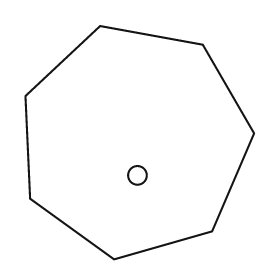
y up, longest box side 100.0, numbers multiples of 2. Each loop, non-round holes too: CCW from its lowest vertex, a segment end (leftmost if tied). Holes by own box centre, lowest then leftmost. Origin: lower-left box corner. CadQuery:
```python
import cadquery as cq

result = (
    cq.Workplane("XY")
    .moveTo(38.0, 0.0)
    .lineTo(80.0, 12.0)
    .lineTo(98.0, 54.0)
    .lineTo(76.0, 92.0)
    .lineTo(32.0, 100.0)
    .lineTo(0.0, 70.0)
    .lineTo(2.0, 26.0)
    .close()
    .moveTo(48.0, 36.0)
    .circle(4.0)
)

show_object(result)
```